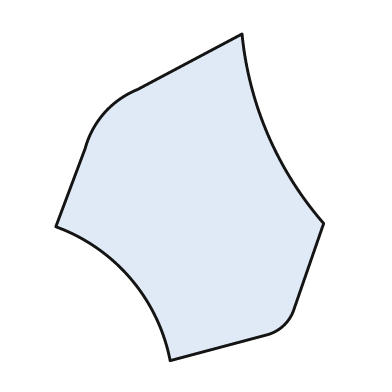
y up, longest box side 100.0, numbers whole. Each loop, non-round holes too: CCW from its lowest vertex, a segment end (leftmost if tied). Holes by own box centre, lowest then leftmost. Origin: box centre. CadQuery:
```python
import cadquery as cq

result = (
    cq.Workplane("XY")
    .moveTo(-6.0, -50.0)
    .lineTo(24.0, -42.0)
    .threePointArc((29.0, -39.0), (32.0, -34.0))
    .lineTo(41.0, -8.0)
    .threePointArc((24.0, 19.0), (16.0, 50.0))
    .lineTo(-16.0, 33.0)
    .threePointArc((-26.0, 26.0), (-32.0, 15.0))
    .lineTo(-41.0, -9.0)
    .threePointArc((-18.0, -25.0), (-6.0, -50.0))
    .close()
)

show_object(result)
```